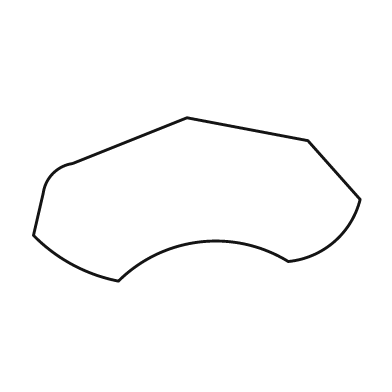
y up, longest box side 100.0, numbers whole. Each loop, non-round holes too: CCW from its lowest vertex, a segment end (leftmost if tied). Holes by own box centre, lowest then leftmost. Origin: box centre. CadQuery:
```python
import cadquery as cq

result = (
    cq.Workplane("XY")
    .moveTo(-24.0, -25.0)
    .threePointArc((1.0, -13.0), (28.0, -19.0))
    .threePointArc((42.0, -13.0), (50.0, 0.0))
    .lineTo(34.0, 18.0)
    .lineTo(-3.0, 25.0)
    .lineTo(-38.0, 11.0)
    .threePointArc((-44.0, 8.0), (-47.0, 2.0))
    .lineTo(-50.0, -11.0)
    .threePointArc((-38.0, -20.0), (-24.0, -25.0))
    .close()
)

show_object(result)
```